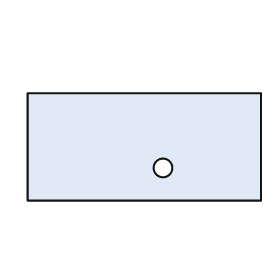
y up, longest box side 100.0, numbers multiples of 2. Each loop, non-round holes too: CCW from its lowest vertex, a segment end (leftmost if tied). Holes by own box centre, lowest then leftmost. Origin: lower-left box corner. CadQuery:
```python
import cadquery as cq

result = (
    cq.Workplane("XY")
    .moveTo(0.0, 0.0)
    .lineTo(100.0, 0.0)
    .lineTo(100.0, 46.0)
    .lineTo(0.0, 46.0)
    .close()
    .moveTo(58.0, 14.0)
    .circle(4.0)
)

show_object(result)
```